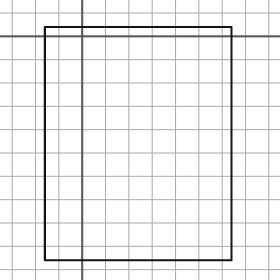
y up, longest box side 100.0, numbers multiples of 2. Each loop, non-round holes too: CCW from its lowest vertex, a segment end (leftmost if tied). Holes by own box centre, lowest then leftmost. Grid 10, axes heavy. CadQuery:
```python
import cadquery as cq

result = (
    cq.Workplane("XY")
    .moveTo(-16.0, -96.0)
    .lineTo(64.0, -96.0)
    .lineTo(64.0, 4.0)
    .lineTo(-16.0, 4.0)
    .close()
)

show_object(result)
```